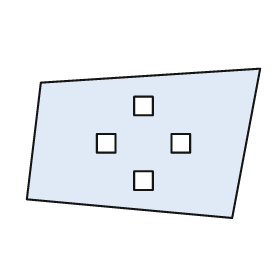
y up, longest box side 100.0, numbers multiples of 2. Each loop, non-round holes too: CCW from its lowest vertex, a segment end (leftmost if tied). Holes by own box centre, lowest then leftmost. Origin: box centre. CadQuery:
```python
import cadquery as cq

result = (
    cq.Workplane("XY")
    .moveTo(38.0, -32.0)
    .lineTo(50.0, 32.0)
    .lineTo(-44.0, 26.0)
    .lineTo(-50.0, -24.0)
    .close()
    .moveTo(-4.0, -20.0)
    .lineTo(4.0, -20.0)
    .lineTo(4.0, -12.0)
    .lineTo(-4.0, -12.0)
    .close()
    .moveTo(-20.0, -4.0)
    .lineTo(-12.0, -4.0)
    .lineTo(-12.0, 4.0)
    .lineTo(-20.0, 4.0)
    .close()
    .moveTo(12.0, -4.0)
    .lineTo(20.0, -4.0)
    .lineTo(20.0, 4.0)
    .lineTo(12.0, 4.0)
    .close()
    .moveTo(-4.0, 12.0)
    .lineTo(4.0, 12.0)
    .lineTo(4.0, 20.0)
    .lineTo(-4.0, 20.0)
    .close()
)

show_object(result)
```